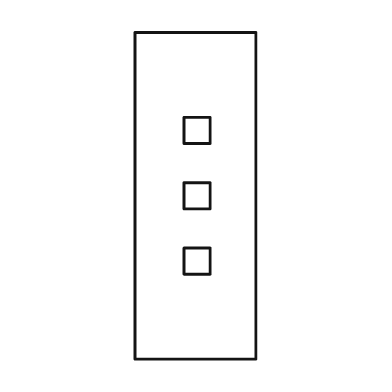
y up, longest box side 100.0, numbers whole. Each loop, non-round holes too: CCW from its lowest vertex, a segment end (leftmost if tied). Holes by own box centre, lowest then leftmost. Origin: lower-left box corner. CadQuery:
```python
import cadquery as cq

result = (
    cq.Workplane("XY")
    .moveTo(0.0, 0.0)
    .lineTo(37.0, 0.0)
    .lineTo(37.0, 100.0)
    .lineTo(0.0, 100.0)
    .close()
    .moveTo(15.0, 26.0)
    .lineTo(23.0, 26.0)
    .lineTo(23.0, 34.0)
    .lineTo(15.0, 34.0)
    .close()
    .moveTo(15.0, 46.0)
    .lineTo(23.0, 46.0)
    .lineTo(23.0, 54.0)
    .lineTo(15.0, 54.0)
    .close()
    .moveTo(15.0, 66.0)
    .lineTo(23.0, 66.0)
    .lineTo(23.0, 74.0)
    .lineTo(15.0, 74.0)
    .close()
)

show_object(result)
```